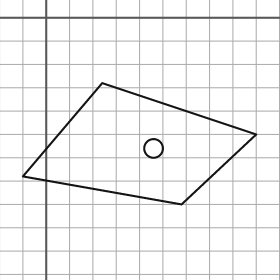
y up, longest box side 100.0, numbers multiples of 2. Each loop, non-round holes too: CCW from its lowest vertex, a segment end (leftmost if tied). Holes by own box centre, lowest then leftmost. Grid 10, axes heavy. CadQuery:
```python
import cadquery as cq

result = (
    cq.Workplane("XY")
    .moveTo(58.0, -80.0)
    .lineTo(90.0, -50.0)
    .lineTo(24.0, -28.0)
    .lineTo(-10.0, -68.0)
    .close()
    .moveTo(46.0, -56.0)
    .circle(4.0)
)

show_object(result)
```